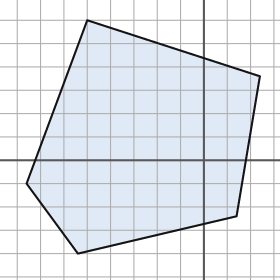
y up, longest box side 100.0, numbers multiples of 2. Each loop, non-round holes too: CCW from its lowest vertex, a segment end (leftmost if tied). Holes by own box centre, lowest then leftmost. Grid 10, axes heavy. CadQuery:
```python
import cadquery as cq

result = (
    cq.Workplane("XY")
    .moveTo(-54.0, -40.0)
    .lineTo(14.0, -24.0)
    .lineTo(24.0, 36.0)
    .lineTo(-50.0, 60.0)
    .lineTo(-76.0, -10.0)
    .close()
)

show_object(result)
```